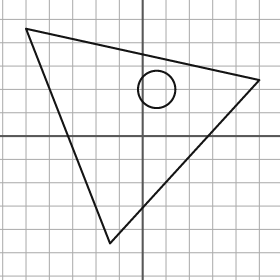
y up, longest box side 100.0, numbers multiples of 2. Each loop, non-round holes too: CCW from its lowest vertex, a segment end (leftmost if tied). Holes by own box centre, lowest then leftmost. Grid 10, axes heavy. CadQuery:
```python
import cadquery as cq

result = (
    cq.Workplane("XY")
    .moveTo(-14.0, -46.0)
    .lineTo(50.0, 24.0)
    .lineTo(-50.0, 46.0)
    .close()
    .moveTo(6.0, 20.0)
    .circle(8.0)
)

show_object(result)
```